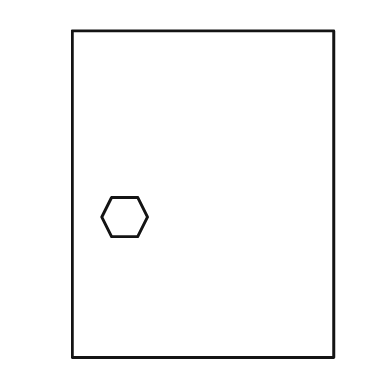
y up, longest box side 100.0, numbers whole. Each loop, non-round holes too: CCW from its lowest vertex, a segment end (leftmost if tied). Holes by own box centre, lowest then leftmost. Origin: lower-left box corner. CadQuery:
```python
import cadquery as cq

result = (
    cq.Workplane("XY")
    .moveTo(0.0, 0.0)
    .lineTo(80.0, 0.0)
    .lineTo(80.0, 100.0)
    .lineTo(0.0, 100.0)
    .close()
    .moveTo(12.0, 37.0)
    .lineTo(20.0, 37.0)
    .lineTo(23.0, 43.0)
    .lineTo(20.0, 49.0)
    .lineTo(12.0, 49.0)
    .lineTo(9.0, 43.0)
    .close()
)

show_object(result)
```